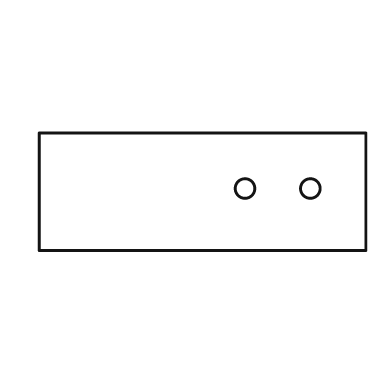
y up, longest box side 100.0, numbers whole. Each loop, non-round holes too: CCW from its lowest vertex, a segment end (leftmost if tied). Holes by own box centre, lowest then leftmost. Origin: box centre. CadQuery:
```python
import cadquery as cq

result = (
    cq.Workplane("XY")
    .moveTo(-50.0, -18.0)
    .lineTo(50.0, -18.0)
    .lineTo(50.0, 18.0)
    .lineTo(-50.0, 18.0)
    .close()
    .moveTo(13.0, 1.0)
    .circle(3.0)
    .moveTo(33.0, 1.0)
    .circle(3.0)
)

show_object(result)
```